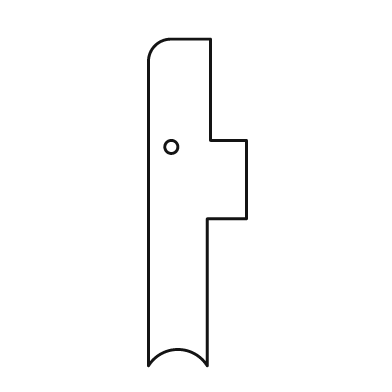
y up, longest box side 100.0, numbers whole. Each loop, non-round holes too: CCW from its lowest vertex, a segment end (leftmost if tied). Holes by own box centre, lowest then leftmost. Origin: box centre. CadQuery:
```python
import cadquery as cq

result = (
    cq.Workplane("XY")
    .moveTo(-15.0, -50.0)
    .threePointArc((-6.0, -45.0), (3.0, -50.0))
    .lineTo(3.0, -5.0)
    .lineTo(15.0, -5.0)
    .lineTo(15.0, 19.0)
    .lineTo(4.0, 19.0)
    .lineTo(4.0, 50.0)
    .lineTo(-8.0, 50.0)
    .threePointArc((-13.0, 48.0), (-15.0, 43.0))
    .close()
    .moveTo(-8.0, 17.0)
    .circle(2.0)
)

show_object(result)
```